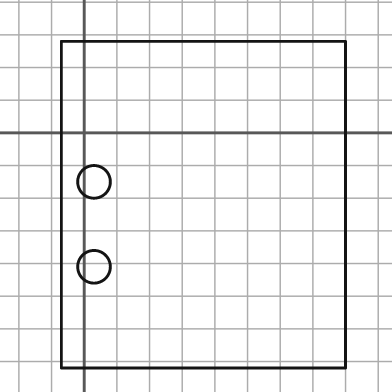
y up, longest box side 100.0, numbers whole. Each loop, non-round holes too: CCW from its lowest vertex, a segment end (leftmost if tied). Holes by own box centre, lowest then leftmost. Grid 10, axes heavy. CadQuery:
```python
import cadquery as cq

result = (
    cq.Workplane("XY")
    .moveTo(-7.0, -72.0)
    .lineTo(80.0, -72.0)
    .lineTo(80.0, 28.0)
    .lineTo(-7.0, 28.0)
    .close()
    .moveTo(3.0, -41.0)
    .circle(5.0)
    .moveTo(3.0, -15.0)
    .circle(5.0)
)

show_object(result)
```